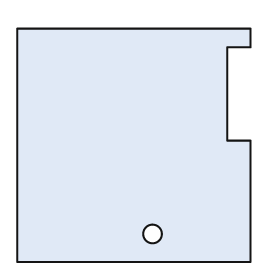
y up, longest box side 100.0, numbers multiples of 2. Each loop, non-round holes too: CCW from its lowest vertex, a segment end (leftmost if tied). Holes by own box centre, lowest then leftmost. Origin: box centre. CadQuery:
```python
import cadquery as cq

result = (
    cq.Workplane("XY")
    .moveTo(-50.0, -50.0)
    .lineTo(50.0, -50.0)
    .lineTo(50.0, 2.0)
    .lineTo(40.0, 2.0)
    .lineTo(40.0, 42.0)
    .lineTo(50.0, 42.0)
    .lineTo(50.0, 50.0)
    .lineTo(-50.0, 50.0)
    .close()
    .moveTo(8.0, -38.0)
    .circle(4.0)
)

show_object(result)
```